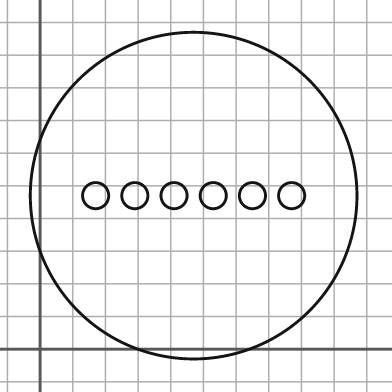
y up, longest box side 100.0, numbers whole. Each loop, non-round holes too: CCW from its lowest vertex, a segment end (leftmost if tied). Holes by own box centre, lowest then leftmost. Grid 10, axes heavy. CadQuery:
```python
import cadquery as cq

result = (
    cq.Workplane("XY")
    .moveTo(47.0, 47.0)
    .circle(50.0)
    .moveTo(17.0, 47.0)
    .circle(4.0)
    .moveTo(29.0, 47.0)
    .circle(4.0)
    .moveTo(41.0, 47.0)
    .circle(4.0)
    .moveTo(53.0, 47.0)
    .circle(4.0)
    .moveTo(65.0, 47.0)
    .circle(4.0)
    .moveTo(77.0, 47.0)
    .circle(4.0)
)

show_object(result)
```